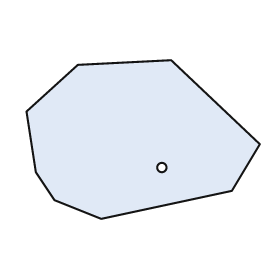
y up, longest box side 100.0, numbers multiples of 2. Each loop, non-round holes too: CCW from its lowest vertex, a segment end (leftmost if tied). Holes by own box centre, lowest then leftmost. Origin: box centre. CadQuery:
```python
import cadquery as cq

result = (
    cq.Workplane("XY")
    .moveTo(-18.0, -34.0)
    .lineTo(38.0, -22.0)
    .lineTo(50.0, -2.0)
    .lineTo(12.0, 34.0)
    .lineTo(-28.0, 32.0)
    .lineTo(-50.0, 12.0)
    .lineTo(-46.0, -14.0)
    .lineTo(-38.0, -26.0)
    .close()
    .moveTo(8.0, -12.0)
    .circle(2.0)
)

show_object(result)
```